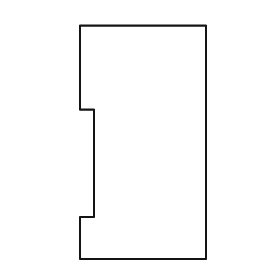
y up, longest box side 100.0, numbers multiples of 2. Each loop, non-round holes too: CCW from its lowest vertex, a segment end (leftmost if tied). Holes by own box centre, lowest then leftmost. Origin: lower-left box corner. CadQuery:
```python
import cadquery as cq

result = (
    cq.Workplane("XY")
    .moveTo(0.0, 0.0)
    .lineTo(54.0, 0.0)
    .lineTo(54.0, 100.0)
    .lineTo(0.0, 100.0)
    .lineTo(0.0, 64.0)
    .lineTo(6.0, 64.0)
    .lineTo(6.0, 18.0)
    .lineTo(0.0, 18.0)
    .close()
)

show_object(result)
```